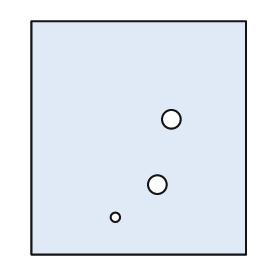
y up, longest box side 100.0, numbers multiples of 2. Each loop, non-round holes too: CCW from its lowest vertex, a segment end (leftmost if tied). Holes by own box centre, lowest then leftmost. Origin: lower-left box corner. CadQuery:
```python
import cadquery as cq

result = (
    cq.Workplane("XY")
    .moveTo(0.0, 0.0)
    .lineTo(92.0, 0.0)
    .lineTo(92.0, 100.0)
    .lineTo(0.0, 100.0)
    .close()
    .moveTo(36.0, 16.0)
    .circle(2.0)
    .moveTo(54.0, 30.0)
    .circle(4.0)
    .moveTo(60.0, 58.0)
    .circle(4.0)
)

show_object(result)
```